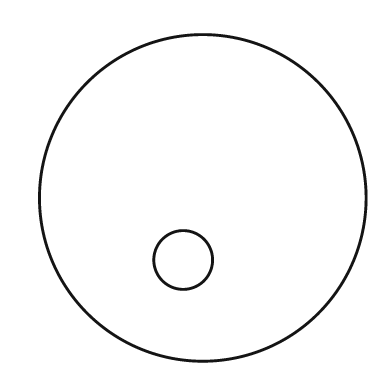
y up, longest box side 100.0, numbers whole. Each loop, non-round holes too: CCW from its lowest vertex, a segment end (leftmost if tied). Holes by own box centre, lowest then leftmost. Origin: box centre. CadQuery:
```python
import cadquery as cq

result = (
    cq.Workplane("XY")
    .moveTo(0.0, 0.0)
    .circle(50.0)
    .moveTo(-6.0, -19.0)
    .circle(9.0)
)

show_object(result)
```